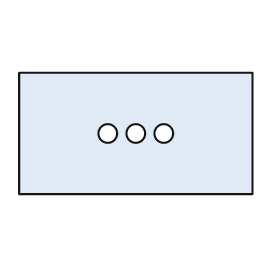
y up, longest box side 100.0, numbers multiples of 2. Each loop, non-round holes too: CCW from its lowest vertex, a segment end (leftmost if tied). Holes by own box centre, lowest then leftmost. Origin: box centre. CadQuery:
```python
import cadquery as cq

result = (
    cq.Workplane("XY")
    .moveTo(-50.0, -26.0)
    .lineTo(50.0, -26.0)
    .lineTo(50.0, 26.0)
    .lineTo(-50.0, 26.0)
    .close()
    .moveTo(-12.0, 0.0)
    .circle(4.0)
    .moveTo(0.0, 0.0)
    .circle(4.0)
    .moveTo(12.0, 0.0)
    .circle(4.0)
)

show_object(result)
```